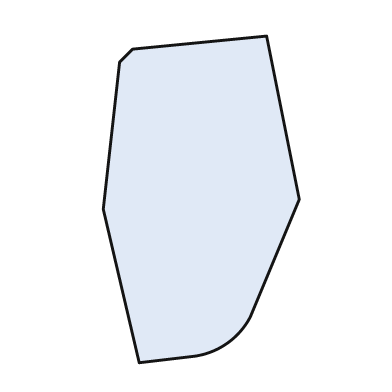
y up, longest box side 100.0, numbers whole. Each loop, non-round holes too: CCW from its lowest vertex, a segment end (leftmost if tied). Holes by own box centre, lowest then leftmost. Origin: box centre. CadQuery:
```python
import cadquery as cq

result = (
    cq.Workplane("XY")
    .moveTo(-19.0, -50.0)
    .lineTo(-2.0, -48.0)
    .threePointArc((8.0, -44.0), (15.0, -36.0))
    .lineTo(30.0, 0.0)
    .lineTo(20.0, 50.0)
    .lineTo(-21.0, 46.0)
    .lineTo(-25.0, 42.0)
    .lineTo(-30.0, -3.0)
    .close()
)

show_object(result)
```